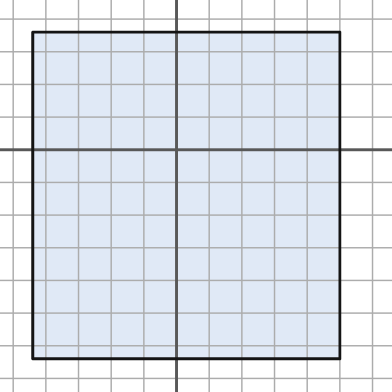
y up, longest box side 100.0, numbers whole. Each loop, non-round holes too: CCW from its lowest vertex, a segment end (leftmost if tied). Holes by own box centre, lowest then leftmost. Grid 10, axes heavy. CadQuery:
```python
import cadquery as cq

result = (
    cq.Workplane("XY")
    .moveTo(-44.0, -64.0)
    .lineTo(50.0, -64.0)
    .lineTo(50.0, 36.0)
    .lineTo(-44.0, 36.0)
    .close()
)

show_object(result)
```